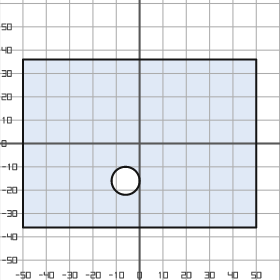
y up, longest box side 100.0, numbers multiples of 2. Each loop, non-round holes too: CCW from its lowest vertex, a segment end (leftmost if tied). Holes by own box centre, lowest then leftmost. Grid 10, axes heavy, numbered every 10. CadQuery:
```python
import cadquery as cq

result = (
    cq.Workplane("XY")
    .moveTo(-50.0, -36.0)
    .lineTo(50.0, -36.0)
    .lineTo(50.0, 36.0)
    .lineTo(-50.0, 36.0)
    .close()
    .moveTo(-6.0, -16.0)
    .circle(6.0)
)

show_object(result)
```